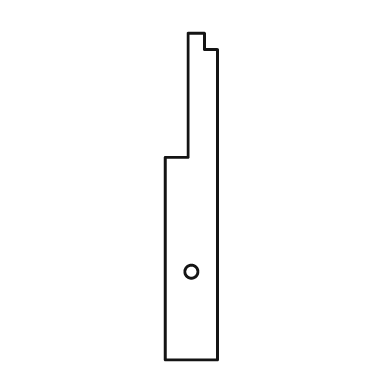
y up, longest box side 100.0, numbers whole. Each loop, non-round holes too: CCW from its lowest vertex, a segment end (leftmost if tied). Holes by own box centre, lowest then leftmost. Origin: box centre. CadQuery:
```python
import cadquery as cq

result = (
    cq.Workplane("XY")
    .moveTo(-8.0, -50.0)
    .lineTo(8.0, -50.0)
    .lineTo(8.0, 45.0)
    .lineTo(4.0, 45.0)
    .lineTo(4.0, 50.0)
    .lineTo(-1.0, 50.0)
    .lineTo(-1.0, 12.0)
    .lineTo(-8.0, 12.0)
    .close()
    .moveTo(0.0, -23.0)
    .circle(2.0)
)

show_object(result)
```